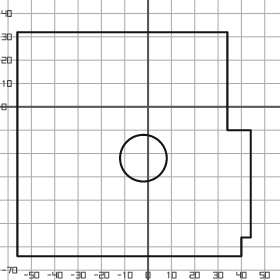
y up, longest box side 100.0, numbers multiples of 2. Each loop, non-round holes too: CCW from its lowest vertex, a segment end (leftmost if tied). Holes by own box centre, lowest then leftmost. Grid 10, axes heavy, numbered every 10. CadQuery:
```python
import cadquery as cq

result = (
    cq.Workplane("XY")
    .moveTo(-56.0, -64.0)
    .lineTo(40.0, -64.0)
    .lineTo(40.0, -56.0)
    .lineTo(44.0, -56.0)
    .lineTo(44.0, -10.0)
    .lineTo(34.0, -10.0)
    .lineTo(34.0, 32.0)
    .lineTo(-56.0, 32.0)
    .close()
    .moveTo(-2.0, -22.0)
    .circle(10.0)
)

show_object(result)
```